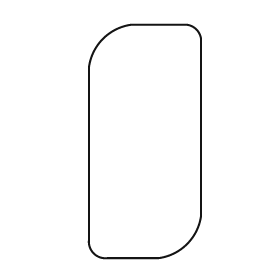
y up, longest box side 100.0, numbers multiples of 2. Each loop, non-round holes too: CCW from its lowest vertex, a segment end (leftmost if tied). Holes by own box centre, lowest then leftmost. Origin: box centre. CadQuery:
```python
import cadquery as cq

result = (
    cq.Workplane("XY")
    .moveTo(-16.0, -50.0)
    .lineTo(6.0, -50.0)
    .threePointArc((18.0, -44.0), (24.0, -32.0))
    .lineTo(24.0, 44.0)
    .threePointArc((22.0, 48.0), (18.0, 50.0))
    .lineTo(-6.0, 50.0)
    .threePointArc((-18.0, 44.0), (-24.0, 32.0))
    .lineTo(-24.0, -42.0)
    .threePointArc((-22.0, -48.0), (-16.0, -50.0))
    .close()
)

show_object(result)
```